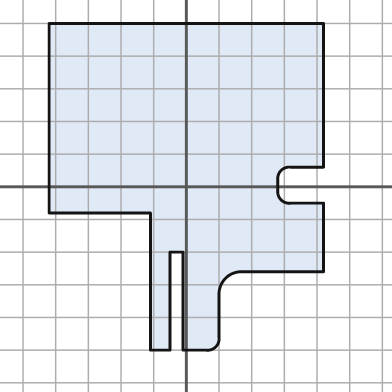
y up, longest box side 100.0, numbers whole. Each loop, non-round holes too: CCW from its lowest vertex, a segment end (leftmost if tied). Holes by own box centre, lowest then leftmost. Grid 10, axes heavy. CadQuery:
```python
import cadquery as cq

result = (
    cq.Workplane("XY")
    .moveTo(-11.0, -50.0)
    .lineTo(-5.0, -50.0)
    .lineTo(-5.0, -20.0)
    .lineTo(-1.0, -20.0)
    .lineTo(-1.0, -50.0)
    .lineTo(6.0, -50.0)
    .threePointArc((9.0, -49.0), (10.0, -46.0))
    .lineTo(10.0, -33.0)
    .threePointArc((12.0, -28.0), (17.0, -26.0))
    .lineTo(42.0, -26.0)
    .lineTo(42.0, -5.0)
    .lineTo(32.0, -5.0)
    .threePointArc((29.0, -4.0), (28.0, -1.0))
    .lineTo(28.0, 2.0)
    .threePointArc((29.0, 5.0), (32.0, 6.0))
    .lineTo(42.0, 6.0)
    .lineTo(42.0, 50.0)
    .lineTo(-42.0, 50.0)
    .lineTo(-42.0, -8.0)
    .lineTo(-11.0, -8.0)
    .close()
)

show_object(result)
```